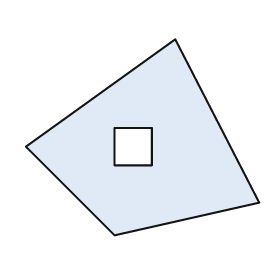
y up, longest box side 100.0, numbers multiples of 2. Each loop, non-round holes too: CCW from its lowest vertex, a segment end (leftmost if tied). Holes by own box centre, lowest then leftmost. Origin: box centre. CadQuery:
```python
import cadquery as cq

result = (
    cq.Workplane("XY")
    .moveTo(-12.0, -42.0)
    .lineTo(50.0, -28.0)
    .lineTo(14.0, 42.0)
    .lineTo(-50.0, -4.0)
    .close()
    .moveTo(-12.0, -12.0)
    .lineTo(4.0, -12.0)
    .lineTo(4.0, 4.0)
    .lineTo(-12.0, 4.0)
    .close()
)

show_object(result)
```